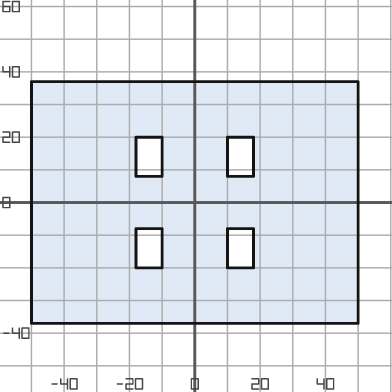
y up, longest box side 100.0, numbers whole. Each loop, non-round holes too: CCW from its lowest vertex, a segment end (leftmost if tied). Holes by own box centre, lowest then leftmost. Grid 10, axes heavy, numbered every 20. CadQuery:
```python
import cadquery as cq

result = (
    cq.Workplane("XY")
    .moveTo(-50.0, -37.0)
    .lineTo(50.0, -37.0)
    .lineTo(50.0, 37.0)
    .lineTo(-50.0, 37.0)
    .close()
    .moveTo(-18.0, -20.0)
    .lineTo(-10.0, -20.0)
    .lineTo(-10.0, -8.0)
    .lineTo(-18.0, -8.0)
    .close()
    .moveTo(10.0, -20.0)
    .lineTo(18.0, -20.0)
    .lineTo(18.0, -8.0)
    .lineTo(10.0, -8.0)
    .close()
    .moveTo(-18.0, 8.0)
    .lineTo(-10.0, 8.0)
    .lineTo(-10.0, 20.0)
    .lineTo(-18.0, 20.0)
    .close()
    .moveTo(10.0, 8.0)
    .lineTo(18.0, 8.0)
    .lineTo(18.0, 20.0)
    .lineTo(10.0, 20.0)
    .close()
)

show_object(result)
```